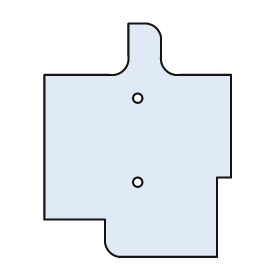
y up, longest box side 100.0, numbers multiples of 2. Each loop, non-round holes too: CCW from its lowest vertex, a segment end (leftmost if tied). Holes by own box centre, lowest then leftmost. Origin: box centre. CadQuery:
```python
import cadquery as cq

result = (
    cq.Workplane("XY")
    .moveTo(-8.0, -50.0)
    .lineTo(34.0, -50.0)
    .lineTo(34.0, -16.0)
    .lineTo(40.0, -16.0)
    .lineTo(40.0, 28.0)
    .lineTo(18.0, 28.0)
    .threePointArc((12.0, 30.0), (10.0, 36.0))
    .lineTo(10.0, 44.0)
    .threePointArc((8.0, 48.0), (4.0, 50.0))
    .lineTo(-4.0, 50.0)
    .lineTo(-4.0, 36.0)
    .threePointArc((-6.0, 30.0), (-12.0, 28.0))
    .lineTo(-40.0, 28.0)
    .lineTo(-40.0, -34.0)
    .lineTo(-14.0, -34.0)
    .lineTo(-14.0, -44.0)
    .threePointArc((-12.0, -48.0), (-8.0, -50.0))
    .close()
    .moveTo(0.0, -18.0)
    .circle(2.0)
    .moveTo(0.0, 18.0)
    .circle(2.0)
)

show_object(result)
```